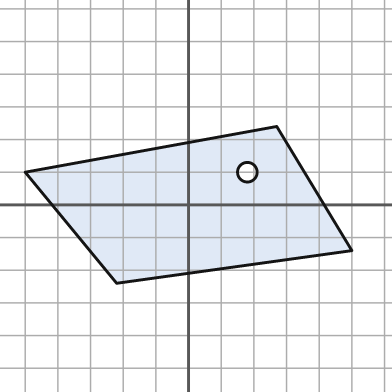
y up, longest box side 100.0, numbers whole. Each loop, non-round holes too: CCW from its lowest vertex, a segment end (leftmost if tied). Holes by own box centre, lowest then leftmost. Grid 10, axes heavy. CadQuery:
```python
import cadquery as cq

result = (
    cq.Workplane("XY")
    .moveTo(-22.0, -24.0)
    .lineTo(50.0, -14.0)
    .lineTo(27.0, 24.0)
    .lineTo(-50.0, 10.0)
    .close()
    .moveTo(18.0, 10.0)
    .circle(3.0)
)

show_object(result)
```